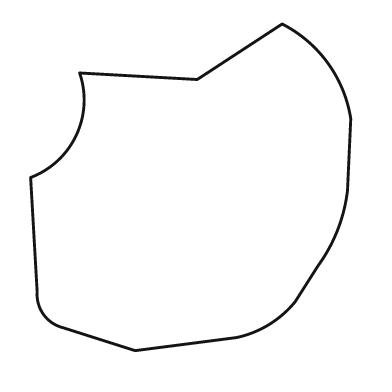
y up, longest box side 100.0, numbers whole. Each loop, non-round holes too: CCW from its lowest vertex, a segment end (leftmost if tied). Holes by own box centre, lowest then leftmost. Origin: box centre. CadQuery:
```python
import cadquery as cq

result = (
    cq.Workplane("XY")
    .moveTo(-17.0, -50.0)
    .lineTo(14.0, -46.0)
    .threePointArc((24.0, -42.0), (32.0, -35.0))
    .lineTo(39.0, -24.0)
    .threePointArc((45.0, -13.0), (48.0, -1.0))
    .lineTo(49.0, 21.0)
    .threePointArc((42.0, 38.0), (28.0, 50.0))
    .lineTo(2.0, 33.0)
    .lineTo(-34.0, 35.0)
    .threePointArc((-35.0, 16.0), (-49.0, 3.0))
    .lineTo(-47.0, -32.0)
    .threePointArc((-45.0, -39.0), (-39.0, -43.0))
    .close()
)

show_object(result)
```